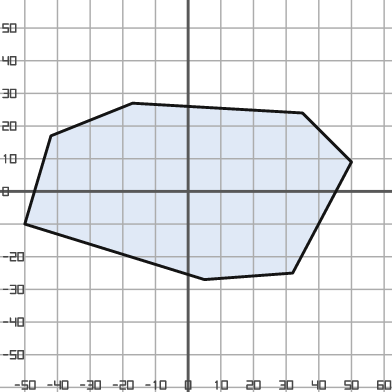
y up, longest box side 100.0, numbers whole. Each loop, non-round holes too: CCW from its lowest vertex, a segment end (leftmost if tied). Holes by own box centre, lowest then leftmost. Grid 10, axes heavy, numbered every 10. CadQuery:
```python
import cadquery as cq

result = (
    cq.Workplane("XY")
    .moveTo(5.0, -27.0)
    .lineTo(32.0, -25.0)
    .lineTo(50.0, 9.0)
    .lineTo(35.0, 24.0)
    .lineTo(-17.0, 27.0)
    .lineTo(-42.0, 17.0)
    .lineTo(-50.0, -10.0)
    .close()
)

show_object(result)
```